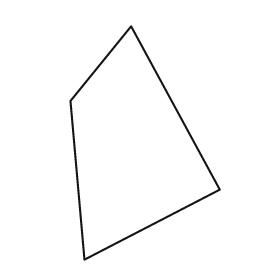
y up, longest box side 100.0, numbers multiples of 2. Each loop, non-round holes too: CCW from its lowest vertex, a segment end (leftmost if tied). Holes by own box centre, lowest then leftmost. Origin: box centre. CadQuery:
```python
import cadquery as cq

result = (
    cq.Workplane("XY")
    .moveTo(-26.0, -50.0)
    .lineTo(32.0, -20.0)
    .lineTo(-6.0, 50.0)
    .lineTo(-32.0, 18.0)
    .close()
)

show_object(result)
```